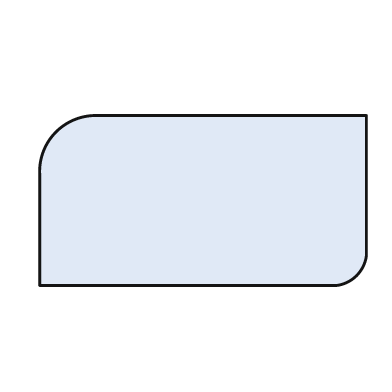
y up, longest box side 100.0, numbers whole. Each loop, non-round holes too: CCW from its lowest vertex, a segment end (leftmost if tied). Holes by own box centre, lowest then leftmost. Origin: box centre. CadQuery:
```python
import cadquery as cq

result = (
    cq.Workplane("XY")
    .moveTo(-50.0, -26.0)
    .lineTo(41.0, -26.0)
    .threePointArc((47.0, -23.0), (50.0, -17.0))
    .lineTo(50.0, 26.0)
    .lineTo(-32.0, 26.0)
    .threePointArc((-45.0, 21.0), (-50.0, 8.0))
    .close()
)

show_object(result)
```